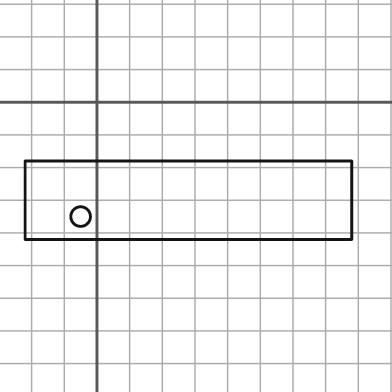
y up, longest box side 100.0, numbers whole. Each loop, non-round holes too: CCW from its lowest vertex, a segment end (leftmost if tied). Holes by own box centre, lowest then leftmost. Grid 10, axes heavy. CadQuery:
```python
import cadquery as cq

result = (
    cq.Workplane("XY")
    .moveTo(-22.0, -42.0)
    .lineTo(78.0, -42.0)
    .lineTo(78.0, -18.0)
    .lineTo(-22.0, -18.0)
    .close()
    .moveTo(-5.0, -35.0)
    .circle(3.0)
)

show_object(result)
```